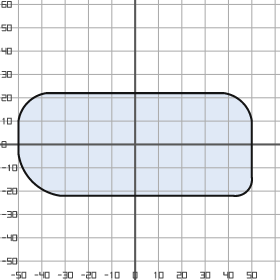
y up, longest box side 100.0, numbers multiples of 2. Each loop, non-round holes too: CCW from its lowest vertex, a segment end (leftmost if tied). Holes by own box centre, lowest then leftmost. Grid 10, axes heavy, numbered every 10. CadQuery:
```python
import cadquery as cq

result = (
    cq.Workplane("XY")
    .moveTo(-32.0, -22.0)
    .lineTo(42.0, -22.0)
    .threePointArc((48.0, -20.0), (50.0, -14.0))
    .lineTo(50.0, 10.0)
    .threePointArc((46.0, 18.0), (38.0, 22.0))
    .lineTo(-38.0, 22.0)
    .threePointArc((-46.0, 18.0), (-50.0, 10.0))
    .lineTo(-50.0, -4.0)
    .threePointArc((-44.0, -16.0), (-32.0, -22.0))
    .close()
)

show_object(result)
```